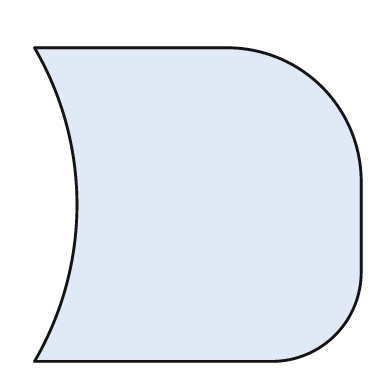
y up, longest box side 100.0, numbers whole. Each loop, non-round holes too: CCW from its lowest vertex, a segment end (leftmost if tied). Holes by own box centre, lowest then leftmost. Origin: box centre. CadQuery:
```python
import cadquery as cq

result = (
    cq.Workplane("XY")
    .moveTo(-50.0, -48.0)
    .lineTo(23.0, -48.0)
    .threePointArc((42.0, -40.0), (50.0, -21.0))
    .lineTo(50.0, 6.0)
    .threePointArc((38.0, 36.0), (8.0, 48.0))
    .lineTo(-50.0, 48.0)
    .threePointArc((-37.0, 0.0), (-50.0, -48.0))
    .close()
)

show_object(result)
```